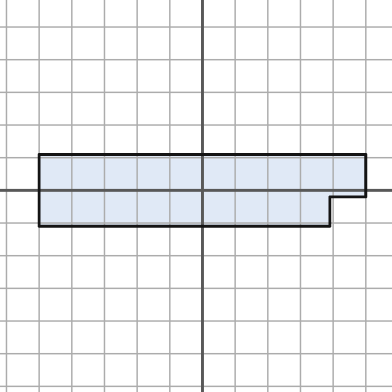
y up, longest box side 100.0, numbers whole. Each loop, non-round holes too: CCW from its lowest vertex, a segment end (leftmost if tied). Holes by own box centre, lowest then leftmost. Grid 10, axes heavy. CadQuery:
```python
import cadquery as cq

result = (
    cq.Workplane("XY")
    .moveTo(-50.0, -11.0)
    .lineTo(39.0, -11.0)
    .lineTo(39.0, -2.0)
    .lineTo(50.0, -2.0)
    .lineTo(50.0, 11.0)
    .lineTo(-50.0, 11.0)
    .close()
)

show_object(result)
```